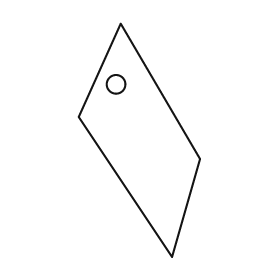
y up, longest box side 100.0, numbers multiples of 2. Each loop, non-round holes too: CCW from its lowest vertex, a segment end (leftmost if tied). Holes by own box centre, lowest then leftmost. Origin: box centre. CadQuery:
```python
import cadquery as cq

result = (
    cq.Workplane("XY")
    .moveTo(14.0, -50.0)
    .lineTo(26.0, -8.0)
    .lineTo(-8.0, 50.0)
    .lineTo(-26.0, 10.0)
    .close()
    .moveTo(-10.0, 24.0)
    .circle(4.0)
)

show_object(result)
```